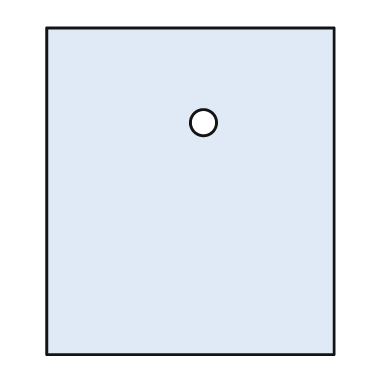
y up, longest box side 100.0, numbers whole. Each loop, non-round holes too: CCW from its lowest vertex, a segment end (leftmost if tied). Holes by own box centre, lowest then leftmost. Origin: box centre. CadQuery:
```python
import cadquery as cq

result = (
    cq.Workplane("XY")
    .moveTo(-44.0, -50.0)
    .lineTo(44.0, -50.0)
    .lineTo(44.0, 50.0)
    .lineTo(-44.0, 50.0)
    .close()
    .moveTo(4.0, 21.0)
    .circle(4.0)
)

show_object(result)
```